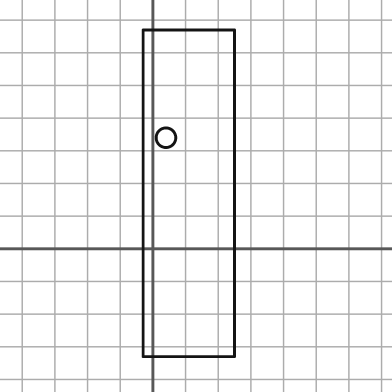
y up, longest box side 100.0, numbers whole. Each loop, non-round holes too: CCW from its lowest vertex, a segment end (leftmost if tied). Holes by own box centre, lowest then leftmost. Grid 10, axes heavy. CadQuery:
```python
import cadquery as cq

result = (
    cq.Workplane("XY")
    .moveTo(-3.0, -33.0)
    .lineTo(25.0, -33.0)
    .lineTo(25.0, 67.0)
    .lineTo(-3.0, 67.0)
    .close()
    .moveTo(4.0, 34.0)
    .circle(3.0)
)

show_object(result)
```